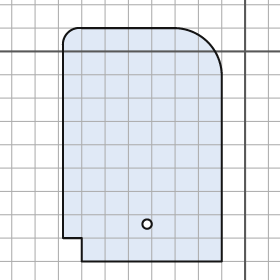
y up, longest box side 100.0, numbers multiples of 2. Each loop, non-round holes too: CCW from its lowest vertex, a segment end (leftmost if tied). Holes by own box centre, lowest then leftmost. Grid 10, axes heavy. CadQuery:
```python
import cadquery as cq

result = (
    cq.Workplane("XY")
    .moveTo(-70.0, -90.0)
    .lineTo(-10.0, -90.0)
    .lineTo(-10.0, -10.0)
    .threePointArc((-16.0, 4.0), (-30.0, 10.0))
    .lineTo(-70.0, 10.0)
    .threePointArc((-76.0, 8.0), (-78.0, 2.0))
    .lineTo(-78.0, -80.0)
    .lineTo(-70.0, -80.0)
    .close()
    .moveTo(-42.0, -74.0)
    .circle(2.0)
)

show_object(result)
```